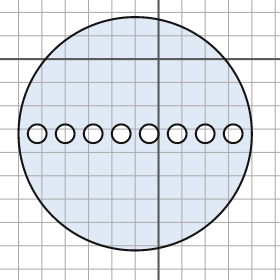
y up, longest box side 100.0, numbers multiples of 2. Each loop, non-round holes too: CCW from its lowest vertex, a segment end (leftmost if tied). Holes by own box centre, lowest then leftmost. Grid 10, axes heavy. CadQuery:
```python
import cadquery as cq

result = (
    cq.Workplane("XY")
    .moveTo(-10.0, -32.0)
    .circle(50.0)
    .moveTo(-52.0, -32.0)
    .circle(4.0)
    .moveTo(-40.0, -32.0)
    .circle(4.0)
    .moveTo(-28.0, -32.0)
    .circle(4.0)
    .moveTo(-16.0, -32.0)
    .circle(4.0)
    .moveTo(-4.0, -32.0)
    .circle(4.0)
    .moveTo(8.0, -32.0)
    .circle(4.0)
    .moveTo(20.0, -32.0)
    .circle(4.0)
    .moveTo(32.0, -32.0)
    .circle(4.0)
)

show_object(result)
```